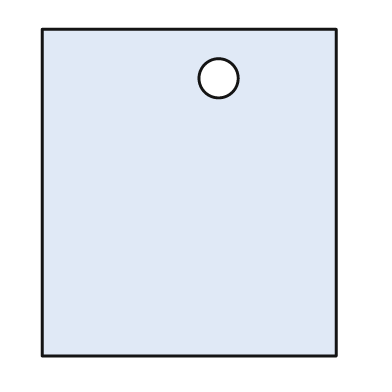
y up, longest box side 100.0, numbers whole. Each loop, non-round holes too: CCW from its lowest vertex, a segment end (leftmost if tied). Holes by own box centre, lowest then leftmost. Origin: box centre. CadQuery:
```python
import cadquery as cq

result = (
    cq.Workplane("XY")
    .moveTo(-45.0, -50.0)
    .lineTo(45.0, -50.0)
    .lineTo(45.0, 50.0)
    .lineTo(-45.0, 50.0)
    .close()
    .moveTo(9.0, 35.0)
    .circle(6.0)
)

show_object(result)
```